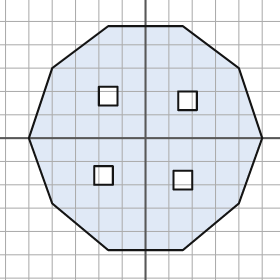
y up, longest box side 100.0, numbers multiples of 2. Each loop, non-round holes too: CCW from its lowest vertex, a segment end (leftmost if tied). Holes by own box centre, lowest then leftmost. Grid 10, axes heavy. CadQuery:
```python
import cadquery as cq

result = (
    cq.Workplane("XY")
    .moveTo(-16.0, -48.0)
    .lineTo(16.0, -48.0)
    .lineTo(40.0, -28.0)
    .lineTo(50.0, 0.0)
    .lineTo(40.0, 30.0)
    .lineTo(16.0, 48.0)
    .lineTo(-16.0, 48.0)
    .lineTo(-40.0, 30.0)
    .lineTo(-50.0, 0.0)
    .lineTo(-40.0, -28.0)
    .close()
    .moveTo(12.0, -22.0)
    .lineTo(20.0, -22.0)
    .lineTo(20.0, -14.0)
    .lineTo(12.0, -14.0)
    .close()
    .moveTo(-22.0, -20.0)
    .lineTo(-14.0, -20.0)
    .lineTo(-14.0, -12.0)
    .lineTo(-22.0, -12.0)
    .close()
    .moveTo(14.0, 12.0)
    .lineTo(22.0, 12.0)
    .lineTo(22.0, 20.0)
    .lineTo(14.0, 20.0)
    .close()
    .moveTo(-20.0, 14.0)
    .lineTo(-12.0, 14.0)
    .lineTo(-12.0, 22.0)
    .lineTo(-20.0, 22.0)
    .close()
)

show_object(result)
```